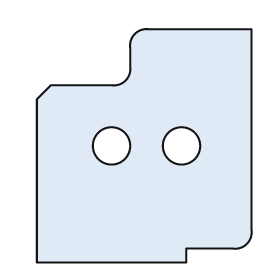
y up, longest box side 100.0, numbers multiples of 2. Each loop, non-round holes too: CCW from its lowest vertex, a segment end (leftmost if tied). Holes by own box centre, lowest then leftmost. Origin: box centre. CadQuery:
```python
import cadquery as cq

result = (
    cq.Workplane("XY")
    .moveTo(-46.0, -50.0)
    .lineTo(18.0, -50.0)
    .lineTo(18.0, -44.0)
    .lineTo(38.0, -44.0)
    .threePointArc((44.0, -42.0), (46.0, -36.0))
    .lineTo(46.0, 50.0)
    .lineTo(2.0, 50.0)
    .threePointArc((-4.0, 48.0), (-6.0, 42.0))
    .lineTo(-6.0, 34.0)
    .threePointArc((-8.0, 28.0), (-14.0, 26.0))
    .lineTo(-40.0, 26.0)
    .lineTo(-46.0, 20.0)
    .close()
    .moveTo(-14.0, 0.0)
    .circle(8.0)
    .moveTo(16.0, 0.0)
    .circle(8.0)
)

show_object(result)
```